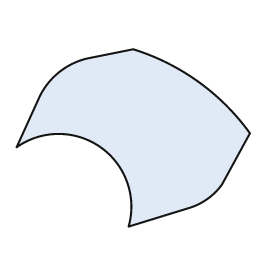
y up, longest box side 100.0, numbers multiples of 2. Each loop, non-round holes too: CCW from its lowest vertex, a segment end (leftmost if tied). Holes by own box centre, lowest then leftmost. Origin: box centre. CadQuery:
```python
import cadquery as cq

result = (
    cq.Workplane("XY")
    .moveTo(-2.0, -38.0)
    .lineTo(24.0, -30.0)
    .threePointArc((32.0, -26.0), (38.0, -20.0))
    .lineTo(50.0, 2.0)
    .threePointArc((28.0, 24.0), (0.0, 38.0))
    .lineTo(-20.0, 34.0)
    .threePointArc((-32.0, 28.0), (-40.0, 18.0))
    .lineTo(-50.0, -4.0)
    .threePointArc((-14.0, -4.0), (-2.0, -38.0))
    .close()
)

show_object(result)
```